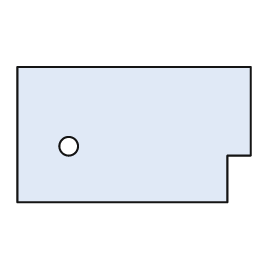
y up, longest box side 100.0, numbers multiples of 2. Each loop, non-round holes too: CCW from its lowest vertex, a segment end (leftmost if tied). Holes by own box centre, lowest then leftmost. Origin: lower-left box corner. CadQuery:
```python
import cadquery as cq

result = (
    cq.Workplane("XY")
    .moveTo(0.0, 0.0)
    .lineTo(90.0, 0.0)
    .lineTo(90.0, 20.0)
    .lineTo(100.0, 20.0)
    .lineTo(100.0, 58.0)
    .lineTo(0.0, 58.0)
    .close()
    .moveTo(22.0, 24.0)
    .circle(4.0)
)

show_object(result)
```